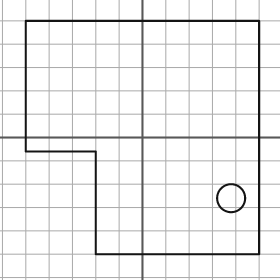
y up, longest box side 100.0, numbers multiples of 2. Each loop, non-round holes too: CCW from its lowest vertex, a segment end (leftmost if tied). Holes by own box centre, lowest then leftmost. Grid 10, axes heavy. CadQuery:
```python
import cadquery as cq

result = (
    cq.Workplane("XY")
    .moveTo(-20.0, -50.0)
    .lineTo(50.0, -50.0)
    .lineTo(50.0, 50.0)
    .lineTo(-50.0, 50.0)
    .lineTo(-50.0, -6.0)
    .lineTo(-20.0, -6.0)
    .close()
    .moveTo(38.0, -26.0)
    .circle(6.0)
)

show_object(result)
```